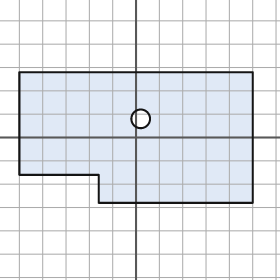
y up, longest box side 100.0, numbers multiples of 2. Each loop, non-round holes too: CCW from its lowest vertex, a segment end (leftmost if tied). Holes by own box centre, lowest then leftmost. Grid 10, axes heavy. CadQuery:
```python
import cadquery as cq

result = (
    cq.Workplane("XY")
    .moveTo(-16.0, -28.0)
    .lineTo(50.0, -28.0)
    .lineTo(50.0, 28.0)
    .lineTo(-50.0, 28.0)
    .lineTo(-50.0, -16.0)
    .lineTo(-16.0, -16.0)
    .close()
    .moveTo(2.0, 8.0)
    .circle(4.0)
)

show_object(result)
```